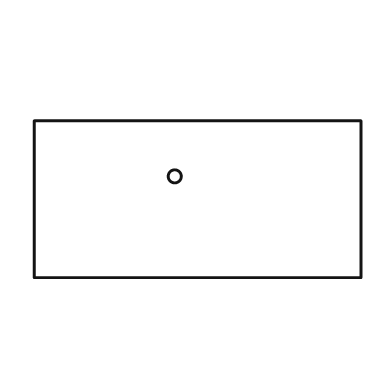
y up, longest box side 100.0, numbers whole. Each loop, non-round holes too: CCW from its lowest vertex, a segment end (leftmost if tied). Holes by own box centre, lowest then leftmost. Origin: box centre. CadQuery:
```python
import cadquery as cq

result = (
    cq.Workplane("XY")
    .moveTo(-50.0, -24.0)
    .lineTo(50.0, -24.0)
    .lineTo(50.0, 24.0)
    .lineTo(-50.0, 24.0)
    .close()
    .moveTo(-7.0, 7.0)
    .circle(2.0)
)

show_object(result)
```